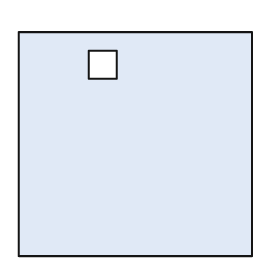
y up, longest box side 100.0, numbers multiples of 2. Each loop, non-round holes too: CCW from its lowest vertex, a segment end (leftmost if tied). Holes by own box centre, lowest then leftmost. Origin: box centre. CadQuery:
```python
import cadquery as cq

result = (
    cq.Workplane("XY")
    .moveTo(-50.0, -48.0)
    .lineTo(50.0, -48.0)
    .lineTo(50.0, 48.0)
    .lineTo(-50.0, 48.0)
    .close()
    .moveTo(-20.0, 28.0)
    .lineTo(-8.0, 28.0)
    .lineTo(-8.0, 40.0)
    .lineTo(-20.0, 40.0)
    .close()
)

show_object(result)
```